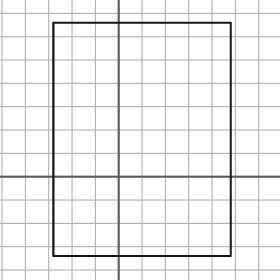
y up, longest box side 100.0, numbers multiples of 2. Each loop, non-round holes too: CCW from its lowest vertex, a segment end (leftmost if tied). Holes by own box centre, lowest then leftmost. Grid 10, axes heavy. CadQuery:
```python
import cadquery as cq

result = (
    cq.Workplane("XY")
    .moveTo(-28.0, -34.0)
    .lineTo(48.0, -34.0)
    .lineTo(48.0, 66.0)
    .lineTo(-28.0, 66.0)
    .close()
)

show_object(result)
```